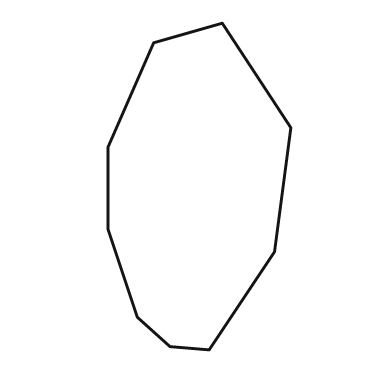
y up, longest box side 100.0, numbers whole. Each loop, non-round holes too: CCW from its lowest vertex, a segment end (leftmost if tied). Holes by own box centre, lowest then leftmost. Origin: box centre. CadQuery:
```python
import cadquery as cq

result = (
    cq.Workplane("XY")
    .moveTo(3.0, -50.0)
    .lineTo(23.0, -20.0)
    .lineTo(28.0, 18.0)
    .lineTo(7.0, 50.0)
    .lineTo(-14.0, 44.0)
    .lineTo(-28.0, 12.0)
    .lineTo(-28.0, -13.0)
    .lineTo(-19.0, -40.0)
    .lineTo(-9.0, -49.0)
    .close()
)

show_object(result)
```